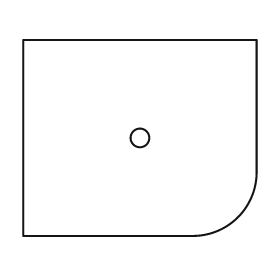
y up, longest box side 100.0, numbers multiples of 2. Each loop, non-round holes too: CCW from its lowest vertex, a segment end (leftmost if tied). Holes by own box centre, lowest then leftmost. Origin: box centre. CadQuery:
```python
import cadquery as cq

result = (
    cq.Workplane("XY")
    .moveTo(-50.0, -42.0)
    .lineTo(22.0, -42.0)
    .threePointArc((42.0, -34.0), (50.0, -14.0))
    .lineTo(50.0, 42.0)
    .lineTo(-50.0, 42.0)
    .close()
    .moveTo(0.0, 0.0)
    .circle(4.0)
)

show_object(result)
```